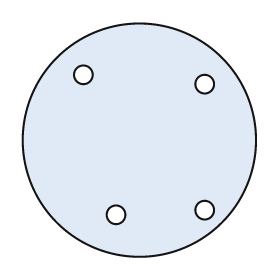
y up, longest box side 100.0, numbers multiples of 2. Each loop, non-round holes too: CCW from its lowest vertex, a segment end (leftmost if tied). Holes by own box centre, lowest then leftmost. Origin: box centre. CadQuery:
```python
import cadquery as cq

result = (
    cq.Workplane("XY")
    .moveTo(0.0, 0.0)
    .circle(50.0)
    .moveTo(-10.0, -32.0)
    .circle(4.0)
    .moveTo(28.0, -30.0)
    .circle(4.0)
    .moveTo(28.0, 24.0)
    .circle(4.0)
    .moveTo(-24.0, 28.0)
    .circle(4.0)
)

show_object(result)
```